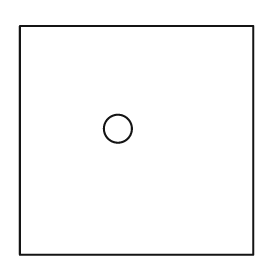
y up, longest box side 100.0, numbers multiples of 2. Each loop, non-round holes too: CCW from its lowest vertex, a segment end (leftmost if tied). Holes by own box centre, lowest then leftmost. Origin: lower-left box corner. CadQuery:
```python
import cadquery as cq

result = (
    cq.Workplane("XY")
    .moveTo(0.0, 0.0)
    .lineTo(100.0, 0.0)
    .lineTo(100.0, 98.0)
    .lineTo(0.0, 98.0)
    .close()
    .moveTo(42.0, 54.0)
    .circle(6.0)
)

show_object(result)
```